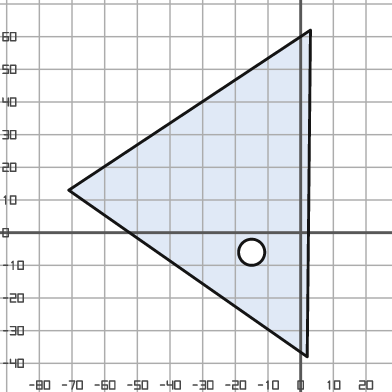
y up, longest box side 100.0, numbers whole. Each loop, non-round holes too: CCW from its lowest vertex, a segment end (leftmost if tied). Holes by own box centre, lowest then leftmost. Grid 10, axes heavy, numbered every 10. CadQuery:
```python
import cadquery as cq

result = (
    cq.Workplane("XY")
    .moveTo(2.0, -38.0)
    .lineTo(3.0, 62.0)
    .lineTo(-71.0, 13.0)
    .close()
    .moveTo(-15.0, -6.0)
    .circle(4.0)
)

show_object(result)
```